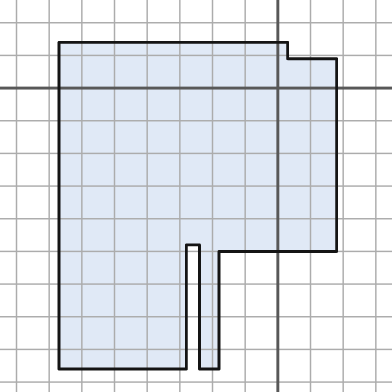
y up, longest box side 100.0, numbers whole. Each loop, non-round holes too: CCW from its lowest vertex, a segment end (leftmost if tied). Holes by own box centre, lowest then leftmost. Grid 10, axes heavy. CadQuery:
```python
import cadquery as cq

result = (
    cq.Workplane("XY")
    .moveTo(-67.0, -86.0)
    .lineTo(-28.0, -86.0)
    .lineTo(-28.0, -48.0)
    .lineTo(-24.0, -48.0)
    .lineTo(-24.0, -86.0)
    .lineTo(-18.0, -86.0)
    .lineTo(-18.0, -50.0)
    .lineTo(18.0, -50.0)
    .lineTo(18.0, 9.0)
    .lineTo(3.0, 9.0)
    .lineTo(3.0, 14.0)
    .lineTo(-67.0, 14.0)
    .close()
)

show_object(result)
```